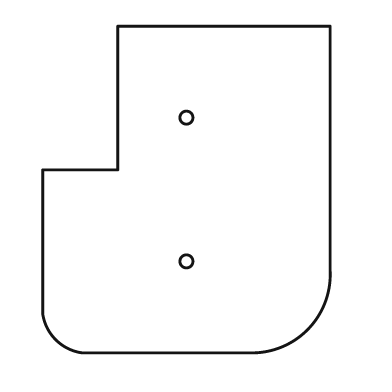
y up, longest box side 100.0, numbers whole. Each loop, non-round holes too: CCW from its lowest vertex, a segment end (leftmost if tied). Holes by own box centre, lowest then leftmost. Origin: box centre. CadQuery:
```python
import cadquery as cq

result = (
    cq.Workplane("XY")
    .moveTo(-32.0, -50.0)
    .lineTo(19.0, -50.0)
    .threePointArc((37.0, -43.0), (44.0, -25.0))
    .lineTo(44.0, 50.0)
    .lineTo(-21.0, 50.0)
    .lineTo(-21.0, 6.0)
    .lineTo(-44.0, 6.0)
    .lineTo(-44.0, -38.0)
    .threePointArc((-40.0, -46.0), (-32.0, -50.0))
    .close()
    .moveTo(0.0, -22.0)
    .circle(2.0)
    .moveTo(0.0, 22.0)
    .circle(2.0)
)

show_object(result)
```